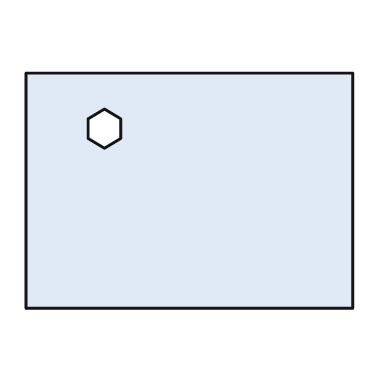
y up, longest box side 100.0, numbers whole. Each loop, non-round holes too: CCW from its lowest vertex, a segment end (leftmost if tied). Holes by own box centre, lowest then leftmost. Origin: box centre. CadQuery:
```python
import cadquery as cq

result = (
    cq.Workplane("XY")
    .moveTo(-50.0, -36.0)
    .lineTo(50.0, -36.0)
    .lineTo(50.0, 36.0)
    .lineTo(-50.0, 36.0)
    .close()
    .moveTo(-26.0, 13.0)
    .lineTo(-21.0, 16.0)
    .lineTo(-21.0, 22.0)
    .lineTo(-26.0, 25.0)
    .lineTo(-31.0, 22.0)
    .lineTo(-31.0, 16.0)
    .close()
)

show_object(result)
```